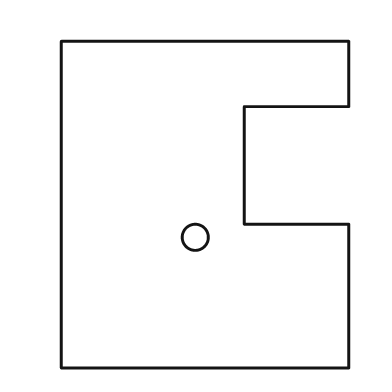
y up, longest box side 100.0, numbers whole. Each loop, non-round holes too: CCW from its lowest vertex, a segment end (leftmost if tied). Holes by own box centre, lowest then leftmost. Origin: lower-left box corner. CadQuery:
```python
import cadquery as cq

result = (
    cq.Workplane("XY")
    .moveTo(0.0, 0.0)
    .lineTo(88.0, 0.0)
    .lineTo(88.0, 44.0)
    .lineTo(56.0, 44.0)
    .lineTo(56.0, 80.0)
    .lineTo(88.0, 80.0)
    .lineTo(88.0, 100.0)
    .lineTo(0.0, 100.0)
    .close()
    .moveTo(41.0, 40.0)
    .circle(4.0)
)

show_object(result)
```